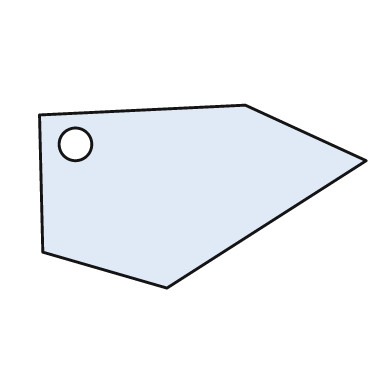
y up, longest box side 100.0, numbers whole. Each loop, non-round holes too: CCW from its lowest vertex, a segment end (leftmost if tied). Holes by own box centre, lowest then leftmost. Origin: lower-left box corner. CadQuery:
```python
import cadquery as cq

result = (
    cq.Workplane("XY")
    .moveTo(39.0, 0.0)
    .lineTo(100.0, 39.0)
    .lineTo(63.0, 56.0)
    .lineTo(0.0, 53.0)
    .lineTo(1.0, 11.0)
    .close()
    .moveTo(11.0, 44.0)
    .circle(5.0)
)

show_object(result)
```